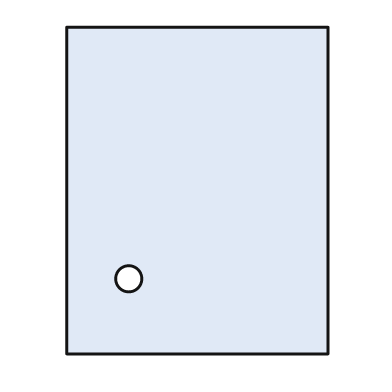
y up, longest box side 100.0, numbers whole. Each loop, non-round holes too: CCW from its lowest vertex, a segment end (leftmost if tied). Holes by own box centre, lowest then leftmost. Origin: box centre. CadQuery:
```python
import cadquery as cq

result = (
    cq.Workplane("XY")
    .moveTo(-40.0, -50.0)
    .lineTo(40.0, -50.0)
    .lineTo(40.0, 50.0)
    .lineTo(-40.0, 50.0)
    .close()
    .moveTo(-21.0, -27.0)
    .circle(4.0)
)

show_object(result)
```